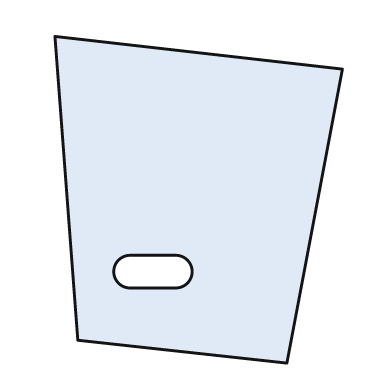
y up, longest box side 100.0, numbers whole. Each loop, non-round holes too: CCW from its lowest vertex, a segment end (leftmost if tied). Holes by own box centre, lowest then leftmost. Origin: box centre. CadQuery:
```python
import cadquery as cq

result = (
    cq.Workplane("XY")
    .moveTo(27.0, -50.0)
    .lineTo(44.0, 40.0)
    .lineTo(-44.0, 50.0)
    .lineTo(-37.0, -43.0)
    .close()
    .moveTo(-21.0, -27.0)
    .lineTo(-7.0, -27.0)
    .threePointArc((-2.0, -22.0), (-7.0, -17.0))
    .lineTo(-21.0, -17.0)
    .threePointArc((-26.0, -22.0), (-21.0, -27.0))
    .close()
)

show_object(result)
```